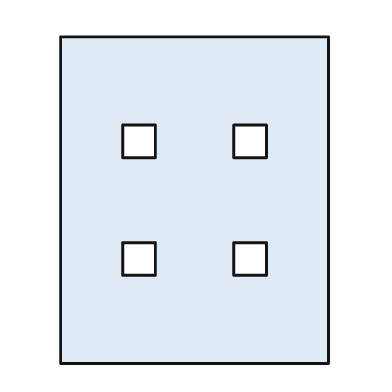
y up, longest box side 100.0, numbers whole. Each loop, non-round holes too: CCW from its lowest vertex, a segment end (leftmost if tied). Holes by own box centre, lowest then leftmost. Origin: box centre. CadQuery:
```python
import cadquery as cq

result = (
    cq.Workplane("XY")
    .moveTo(-41.0, -50.0)
    .lineTo(41.0, -50.0)
    .lineTo(41.0, 50.0)
    .lineTo(-41.0, 50.0)
    .close()
    .moveTo(-22.0, -23.0)
    .lineTo(-12.0, -23.0)
    .lineTo(-12.0, -13.0)
    .lineTo(-22.0, -13.0)
    .close()
    .moveTo(12.0, -23.0)
    .lineTo(22.0, -23.0)
    .lineTo(22.0, -13.0)
    .lineTo(12.0, -13.0)
    .close()
    .moveTo(-22.0, 13.0)
    .lineTo(-12.0, 13.0)
    .lineTo(-12.0, 23.0)
    .lineTo(-22.0, 23.0)
    .close()
    .moveTo(12.0, 13.0)
    .lineTo(22.0, 13.0)
    .lineTo(22.0, 23.0)
    .lineTo(12.0, 23.0)
    .close()
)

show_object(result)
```